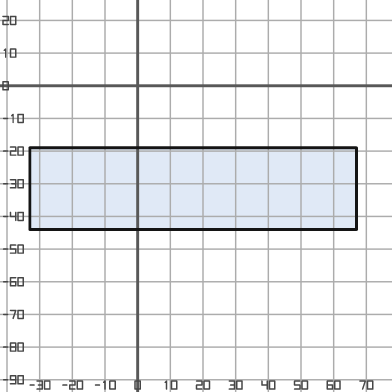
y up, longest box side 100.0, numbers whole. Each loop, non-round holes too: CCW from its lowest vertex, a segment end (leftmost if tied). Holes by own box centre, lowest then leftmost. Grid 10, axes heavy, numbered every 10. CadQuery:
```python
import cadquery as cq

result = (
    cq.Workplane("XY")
    .moveTo(-33.0, -44.0)
    .lineTo(67.0, -44.0)
    .lineTo(67.0, -19.0)
    .lineTo(-33.0, -19.0)
    .close()
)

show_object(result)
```